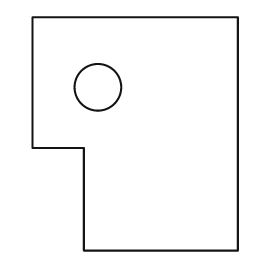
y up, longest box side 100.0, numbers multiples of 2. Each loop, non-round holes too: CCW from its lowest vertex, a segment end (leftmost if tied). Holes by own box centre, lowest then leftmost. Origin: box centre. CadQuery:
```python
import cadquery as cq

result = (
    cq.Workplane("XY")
    .moveTo(-22.0, -50.0)
    .lineTo(44.0, -50.0)
    .lineTo(44.0, 50.0)
    .lineTo(-44.0, 50.0)
    .lineTo(-44.0, -6.0)
    .lineTo(-22.0, -6.0)
    .close()
    .moveTo(-16.0, 20.0)
    .circle(10.0)
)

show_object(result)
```